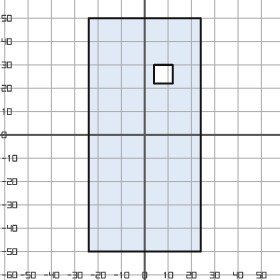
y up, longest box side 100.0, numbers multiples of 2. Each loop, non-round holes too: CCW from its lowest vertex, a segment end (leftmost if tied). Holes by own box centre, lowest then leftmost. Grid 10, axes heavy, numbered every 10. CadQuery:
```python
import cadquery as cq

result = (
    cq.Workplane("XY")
    .moveTo(-24.0, -50.0)
    .lineTo(24.0, -50.0)
    .lineTo(24.0, 50.0)
    .lineTo(-24.0, 50.0)
    .close()
    .moveTo(4.0, 22.0)
    .lineTo(12.0, 22.0)
    .lineTo(12.0, 30.0)
    .lineTo(4.0, 30.0)
    .close()
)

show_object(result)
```